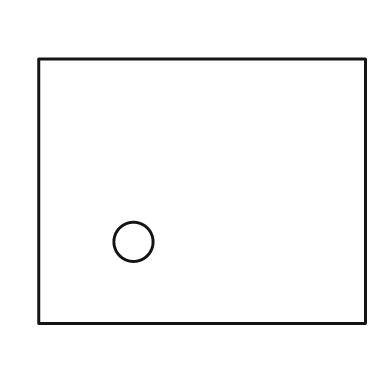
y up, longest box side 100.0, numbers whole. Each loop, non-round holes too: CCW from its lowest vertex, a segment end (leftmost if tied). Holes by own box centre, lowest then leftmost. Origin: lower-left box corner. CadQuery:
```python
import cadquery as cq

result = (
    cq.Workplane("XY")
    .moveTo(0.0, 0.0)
    .lineTo(100.0, 0.0)
    .lineTo(100.0, 81.0)
    .lineTo(0.0, 81.0)
    .close()
    .moveTo(29.0, 25.0)
    .circle(6.0)
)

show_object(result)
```